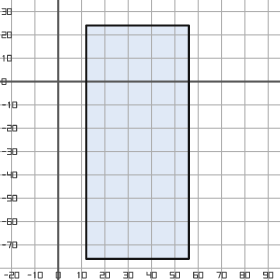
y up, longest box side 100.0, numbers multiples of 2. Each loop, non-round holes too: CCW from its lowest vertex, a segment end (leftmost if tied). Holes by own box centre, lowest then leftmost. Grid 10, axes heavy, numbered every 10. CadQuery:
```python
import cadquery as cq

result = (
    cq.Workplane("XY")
    .moveTo(12.0, -76.0)
    .lineTo(56.0, -76.0)
    .lineTo(56.0, 24.0)
    .lineTo(12.0, 24.0)
    .close()
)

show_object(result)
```